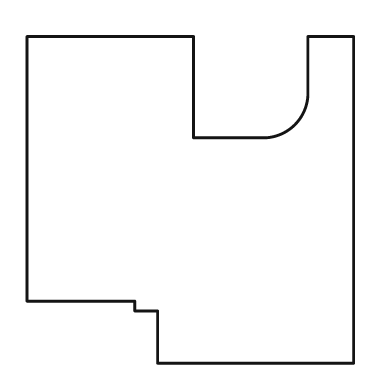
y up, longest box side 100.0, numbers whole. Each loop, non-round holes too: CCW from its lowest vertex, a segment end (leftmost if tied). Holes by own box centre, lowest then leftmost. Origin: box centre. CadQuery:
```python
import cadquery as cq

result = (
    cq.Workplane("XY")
    .moveTo(-10.0, -50.0)
    .lineTo(50.0, -50.0)
    .lineTo(50.0, 50.0)
    .lineTo(36.0, 50.0)
    .lineTo(36.0, 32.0)
    .threePointArc((32.0, 23.0), (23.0, 19.0))
    .lineTo(1.0, 19.0)
    .lineTo(1.0, 50.0)
    .lineTo(-50.0, 50.0)
    .lineTo(-50.0, -31.0)
    .lineTo(-17.0, -31.0)
    .lineTo(-17.0, -34.0)
    .lineTo(-10.0, -34.0)
    .close()
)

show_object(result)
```